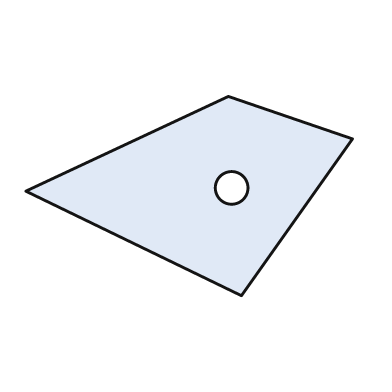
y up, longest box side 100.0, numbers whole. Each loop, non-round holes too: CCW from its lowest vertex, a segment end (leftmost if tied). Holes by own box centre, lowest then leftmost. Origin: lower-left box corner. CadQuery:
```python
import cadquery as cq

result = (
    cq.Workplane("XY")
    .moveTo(66.0, 0.0)
    .lineTo(100.0, 48.0)
    .lineTo(62.0, 61.0)
    .lineTo(0.0, 32.0)
    .close()
    .moveTo(63.0, 33.0)
    .circle(5.0)
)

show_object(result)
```